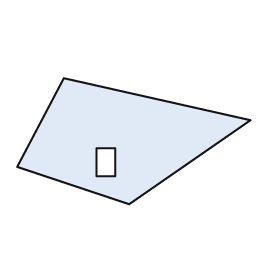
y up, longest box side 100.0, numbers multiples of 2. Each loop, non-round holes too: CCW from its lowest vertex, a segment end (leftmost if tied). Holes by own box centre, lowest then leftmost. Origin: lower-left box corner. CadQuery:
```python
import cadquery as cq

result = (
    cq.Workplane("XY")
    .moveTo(48.0, 0.0)
    .lineTo(100.0, 36.0)
    .lineTo(20.0, 54.0)
    .lineTo(0.0, 16.0)
    .close()
    .moveTo(34.0, 12.0)
    .lineTo(42.0, 12.0)
    .lineTo(42.0, 24.0)
    .lineTo(34.0, 24.0)
    .close()
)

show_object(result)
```